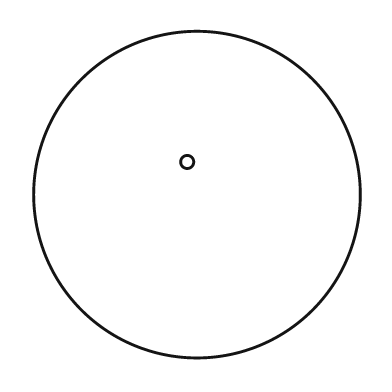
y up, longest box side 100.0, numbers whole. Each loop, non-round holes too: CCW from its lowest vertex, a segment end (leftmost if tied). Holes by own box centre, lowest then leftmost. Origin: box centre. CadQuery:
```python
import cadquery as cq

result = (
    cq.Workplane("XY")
    .moveTo(0.0, 0.0)
    .circle(50.0)
    .moveTo(-3.0, 10.0)
    .circle(2.0)
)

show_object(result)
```